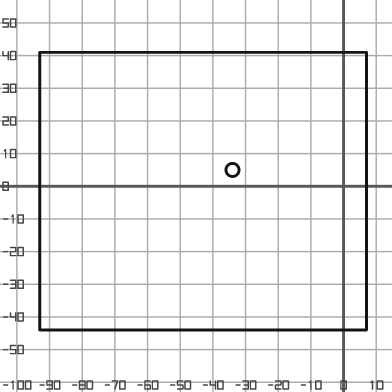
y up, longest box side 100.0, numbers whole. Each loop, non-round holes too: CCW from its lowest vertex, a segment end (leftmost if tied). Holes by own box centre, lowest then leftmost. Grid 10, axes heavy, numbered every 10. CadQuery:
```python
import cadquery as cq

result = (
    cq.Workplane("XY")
    .moveTo(-93.0, -44.0)
    .lineTo(7.0, -44.0)
    .lineTo(7.0, 41.0)
    .lineTo(-93.0, 41.0)
    .close()
    .moveTo(-34.0, 5.0)
    .circle(2.0)
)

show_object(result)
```